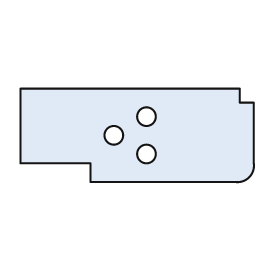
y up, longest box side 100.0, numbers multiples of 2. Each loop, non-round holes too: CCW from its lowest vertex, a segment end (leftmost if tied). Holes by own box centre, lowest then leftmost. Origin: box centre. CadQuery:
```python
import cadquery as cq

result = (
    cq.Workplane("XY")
    .moveTo(-20.0, -20.0)
    .lineTo(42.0, -20.0)
    .threePointArc((48.0, -18.0), (50.0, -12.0))
    .lineTo(50.0, 14.0)
    .lineTo(44.0, 14.0)
    .lineTo(44.0, 20.0)
    .lineTo(-50.0, 20.0)
    .lineTo(-50.0, -12.0)
    .lineTo(-20.0, -12.0)
    .close()
    .moveTo(4.0, -8.0)
    .circle(4.0)
    .moveTo(-10.0, 0.0)
    .circle(4.0)
    .moveTo(4.0, 8.0)
    .circle(4.0)
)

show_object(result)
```